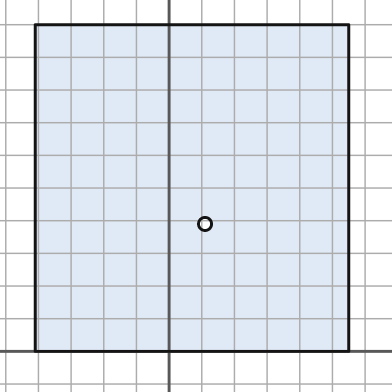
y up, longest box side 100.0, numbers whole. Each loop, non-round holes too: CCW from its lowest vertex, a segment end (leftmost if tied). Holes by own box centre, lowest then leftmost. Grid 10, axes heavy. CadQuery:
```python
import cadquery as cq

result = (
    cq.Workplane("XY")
    .moveTo(-41.0, 0.0)
    .lineTo(55.0, 0.0)
    .lineTo(55.0, 100.0)
    .lineTo(-41.0, 100.0)
    .close()
    .moveTo(11.0, 39.0)
    .circle(2.0)
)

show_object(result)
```